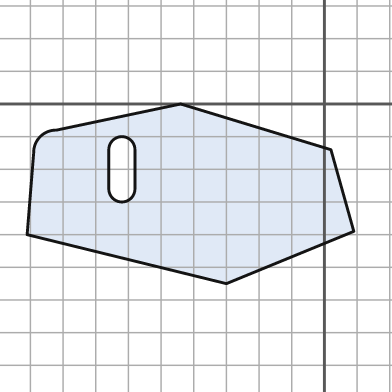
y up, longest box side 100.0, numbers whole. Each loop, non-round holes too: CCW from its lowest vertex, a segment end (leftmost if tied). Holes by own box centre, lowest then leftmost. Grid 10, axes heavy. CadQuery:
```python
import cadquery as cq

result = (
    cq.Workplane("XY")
    .moveTo(-30.0, -55.0)
    .lineTo(9.0, -39.0)
    .lineTo(2.0, -14.0)
    .lineTo(-44.0, 0.0)
    .lineTo(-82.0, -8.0)
    .threePointArc((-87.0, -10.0), (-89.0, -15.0))
    .lineTo(-91.0, -40.0)
    .close()
    .moveTo(-66.0, -26.0)
    .threePointArc((-62.0, -30.0), (-58.0, -26.0))
    .lineTo(-58.0, -14.0)
    .threePointArc((-62.0, -10.0), (-66.0, -14.0))
    .close()
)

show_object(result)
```